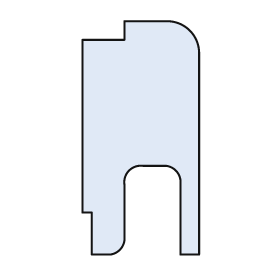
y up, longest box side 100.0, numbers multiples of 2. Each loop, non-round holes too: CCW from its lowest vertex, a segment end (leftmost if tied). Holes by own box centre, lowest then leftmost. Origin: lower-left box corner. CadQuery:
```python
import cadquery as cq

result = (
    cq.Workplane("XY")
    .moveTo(4.0, 0.0)
    .lineTo(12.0, 0.0)
    .threePointArc((16.0, 2.0), (18.0, 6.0))
    .lineTo(18.0, 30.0)
    .threePointArc((20.0, 36.0), (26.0, 38.0))
    .lineTo(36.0, 38.0)
    .threePointArc((40.0, 36.0), (42.0, 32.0))
    .lineTo(42.0, 0.0)
    .lineTo(50.0, 0.0)
    .lineTo(50.0, 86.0)
    .threePointArc((46.0, 96.0), (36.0, 100.0))
    .lineTo(18.0, 100.0)
    .lineTo(18.0, 92.0)
    .lineTo(0.0, 92.0)
    .lineTo(0.0, 18.0)
    .lineTo(4.0, 18.0)
    .close()
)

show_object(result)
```